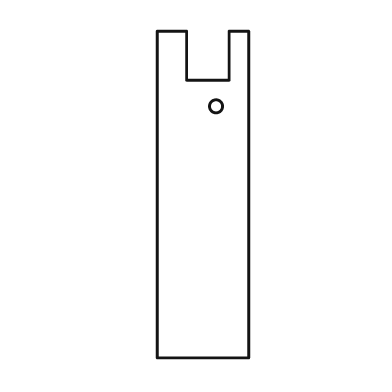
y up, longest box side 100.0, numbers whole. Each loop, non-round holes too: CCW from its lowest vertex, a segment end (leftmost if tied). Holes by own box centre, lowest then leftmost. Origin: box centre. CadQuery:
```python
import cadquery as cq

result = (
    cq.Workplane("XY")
    .moveTo(-14.0, -50.0)
    .lineTo(14.0, -50.0)
    .lineTo(14.0, 50.0)
    .lineTo(8.0, 50.0)
    .lineTo(8.0, 35.0)
    .lineTo(-5.0, 35.0)
    .lineTo(-5.0, 50.0)
    .lineTo(-14.0, 50.0)
    .close()
    .moveTo(4.0, 27.0)
    .circle(2.0)
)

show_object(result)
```